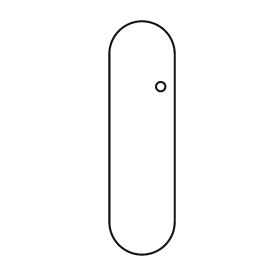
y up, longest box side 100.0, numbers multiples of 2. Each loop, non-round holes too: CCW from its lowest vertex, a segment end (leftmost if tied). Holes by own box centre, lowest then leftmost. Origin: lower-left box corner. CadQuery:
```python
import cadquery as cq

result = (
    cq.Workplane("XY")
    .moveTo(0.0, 14.0)
    .threePointArc((14.0, 0.0), (28.0, 14.0))
    .lineTo(28.0, 86.0)
    .threePointArc((14.0, 100.0), (0.0, 86.0))
    .close()
    .moveTo(22.0, 72.0)
    .circle(2.0)
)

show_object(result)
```